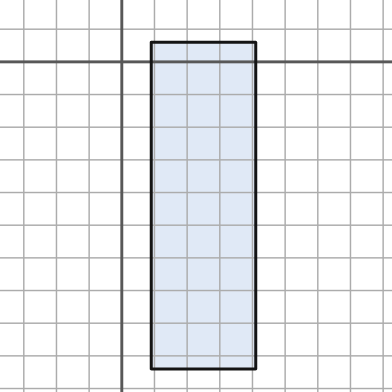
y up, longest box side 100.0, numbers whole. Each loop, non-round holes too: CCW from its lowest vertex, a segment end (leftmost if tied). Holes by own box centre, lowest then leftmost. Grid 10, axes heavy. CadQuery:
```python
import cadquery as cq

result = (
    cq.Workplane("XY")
    .moveTo(9.0, -94.0)
    .lineTo(41.0, -94.0)
    .lineTo(41.0, 6.0)
    .lineTo(9.0, 6.0)
    .close()
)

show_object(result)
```